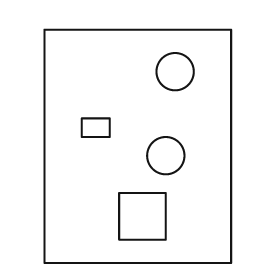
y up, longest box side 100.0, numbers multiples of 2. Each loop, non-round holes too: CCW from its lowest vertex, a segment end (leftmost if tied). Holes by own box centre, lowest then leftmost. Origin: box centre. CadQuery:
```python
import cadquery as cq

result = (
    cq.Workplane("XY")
    .moveTo(-40.0, -50.0)
    .lineTo(40.0, -50.0)
    .lineTo(40.0, 50.0)
    .lineTo(-40.0, 50.0)
    .close()
    .moveTo(-8.0, -40.0)
    .lineTo(12.0, -40.0)
    .lineTo(12.0, -20.0)
    .lineTo(-8.0, -20.0)
    .close()
    .moveTo(12.0, -4.0)
    .circle(8.0)
    .moveTo(-24.0, 4.0)
    .lineTo(-12.0, 4.0)
    .lineTo(-12.0, 12.0)
    .lineTo(-24.0, 12.0)
    .close()
    .moveTo(16.0, 32.0)
    .circle(8.0)
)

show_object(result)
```